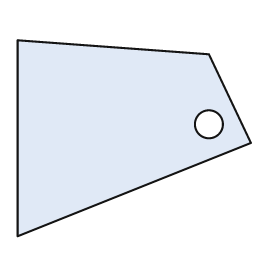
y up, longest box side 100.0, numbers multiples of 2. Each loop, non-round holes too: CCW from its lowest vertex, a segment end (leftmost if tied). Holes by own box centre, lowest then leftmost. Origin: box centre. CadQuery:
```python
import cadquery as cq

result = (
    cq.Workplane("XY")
    .moveTo(-50.0, -42.0)
    .lineTo(50.0, -2.0)
    .lineTo(32.0, 36.0)
    .lineTo(-50.0, 42.0)
    .close()
    .moveTo(32.0, 6.0)
    .circle(6.0)
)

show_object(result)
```